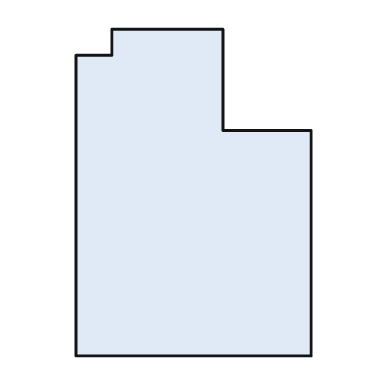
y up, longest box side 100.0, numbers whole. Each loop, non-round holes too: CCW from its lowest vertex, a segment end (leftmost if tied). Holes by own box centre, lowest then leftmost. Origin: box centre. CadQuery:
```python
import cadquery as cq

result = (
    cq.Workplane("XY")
    .moveTo(-36.0, -50.0)
    .lineTo(36.0, -50.0)
    .lineTo(36.0, 19.0)
    .lineTo(9.0, 19.0)
    .lineTo(9.0, 50.0)
    .lineTo(-25.0, 50.0)
    .lineTo(-25.0, 42.0)
    .lineTo(-36.0, 42.0)
    .close()
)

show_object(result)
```